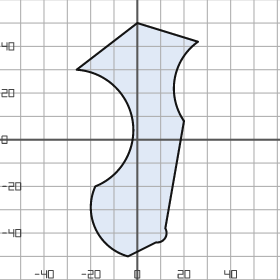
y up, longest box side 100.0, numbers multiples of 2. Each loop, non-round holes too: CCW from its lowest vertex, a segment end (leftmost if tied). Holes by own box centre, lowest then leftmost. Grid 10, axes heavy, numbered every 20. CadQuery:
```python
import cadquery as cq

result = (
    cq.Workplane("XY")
    .moveTo(-4.0, -50.0)
    .lineTo(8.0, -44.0)
    .threePointArc((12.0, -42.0), (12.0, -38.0))
    .lineTo(20.0, 8.0)
    .threePointArc((16.0, 26.0), (26.0, 42.0))
    .lineTo(0.0, 50.0)
    .lineTo(-26.0, 30.0)
    .threePointArc((-2.0, 8.0), (-18.0, -20.0))
    .threePointArc((-18.0, -38.0), (-4.0, -50.0))
    .close()
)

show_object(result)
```